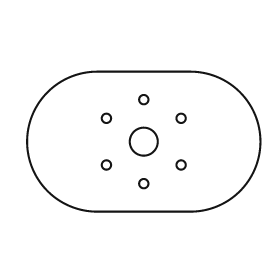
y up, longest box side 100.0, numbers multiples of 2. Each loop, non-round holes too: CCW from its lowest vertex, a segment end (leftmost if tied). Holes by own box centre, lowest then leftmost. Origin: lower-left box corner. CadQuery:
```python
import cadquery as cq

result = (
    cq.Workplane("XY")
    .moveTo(30.0, 0.0)
    .lineTo(70.0, 0.0)
    .threePointArc((100.0, 30.0), (70.0, 60.0))
    .lineTo(30.0, 60.0)
    .threePointArc((0.0, 30.0), (30.0, 0.0))
    .close()
    .moveTo(50.0, 12.0)
    .circle(2.0)
    .moveTo(34.0, 20.0)
    .circle(2.0)
    .moveTo(66.0, 20.0)
    .circle(2.0)
    .moveTo(50.0, 30.0)
    .circle(6.0)
    .moveTo(34.0, 40.0)
    .circle(2.0)
    .moveTo(66.0, 40.0)
    .circle(2.0)
    .moveTo(50.0, 48.0)
    .circle(2.0)
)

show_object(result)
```